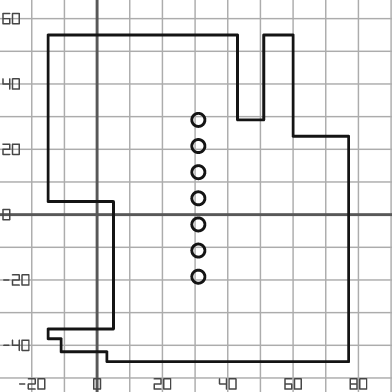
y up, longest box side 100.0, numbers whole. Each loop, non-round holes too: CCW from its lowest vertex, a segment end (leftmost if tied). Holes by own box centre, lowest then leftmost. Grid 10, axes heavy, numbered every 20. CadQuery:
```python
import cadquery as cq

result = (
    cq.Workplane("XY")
    .moveTo(3.0, -45.0)
    .lineTo(77.0, -45.0)
    .lineTo(77.0, 24.0)
    .lineTo(60.0, 24.0)
    .lineTo(60.0, 55.0)
    .lineTo(51.0, 55.0)
    .lineTo(51.0, 29.0)
    .lineTo(43.0, 29.0)
    .lineTo(43.0, 55.0)
    .lineTo(-15.0, 55.0)
    .lineTo(-15.0, 4.0)
    .lineTo(5.0, 4.0)
    .lineTo(5.0, -35.0)
    .lineTo(-15.0, -35.0)
    .lineTo(-15.0, -38.0)
    .lineTo(-11.0, -38.0)
    .lineTo(-11.0, -42.0)
    .lineTo(3.0, -42.0)
    .close()
    .moveTo(31.0, -19.0)
    .circle(2.0)
    .moveTo(31.0, -11.0)
    .circle(2.0)
    .moveTo(31.0, -3.0)
    .circle(2.0)
    .moveTo(31.0, 5.0)
    .circle(2.0)
    .moveTo(31.0, 13.0)
    .circle(2.0)
    .moveTo(31.0, 21.0)
    .circle(2.0)
    .moveTo(31.0, 29.0)
    .circle(2.0)
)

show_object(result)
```